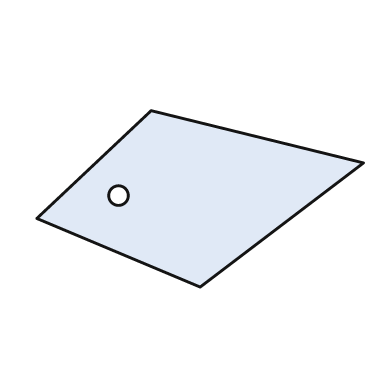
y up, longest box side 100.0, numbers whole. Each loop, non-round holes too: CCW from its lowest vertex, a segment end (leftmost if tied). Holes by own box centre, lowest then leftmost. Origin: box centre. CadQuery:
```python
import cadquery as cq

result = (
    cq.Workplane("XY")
    .moveTo(0.0, -27.0)
    .lineTo(50.0, 11.0)
    .lineTo(-15.0, 27.0)
    .lineTo(-50.0, -6.0)
    .close()
    .moveTo(-25.0, 1.0)
    .circle(3.0)
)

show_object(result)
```